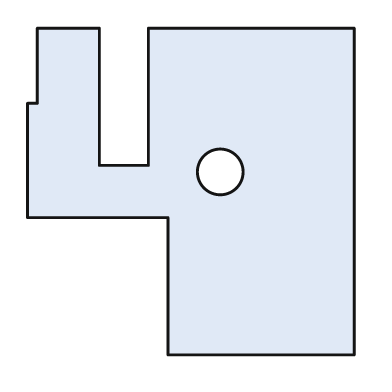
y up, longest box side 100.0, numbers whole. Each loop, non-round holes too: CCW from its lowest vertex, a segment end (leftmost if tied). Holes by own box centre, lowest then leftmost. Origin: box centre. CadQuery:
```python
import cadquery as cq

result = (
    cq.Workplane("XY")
    .moveTo(-7.0, -50.0)
    .lineTo(50.0, -50.0)
    .lineTo(50.0, 50.0)
    .lineTo(-13.0, 50.0)
    .lineTo(-13.0, 8.0)
    .lineTo(-28.0, 8.0)
    .lineTo(-28.0, 50.0)
    .lineTo(-47.0, 50.0)
    .lineTo(-47.0, 27.0)
    .lineTo(-50.0, 27.0)
    .lineTo(-50.0, -8.0)
    .lineTo(-7.0, -8.0)
    .close()
    .moveTo(9.0, 6.0)
    .circle(7.0)
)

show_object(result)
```